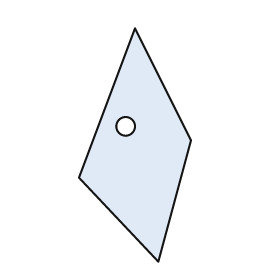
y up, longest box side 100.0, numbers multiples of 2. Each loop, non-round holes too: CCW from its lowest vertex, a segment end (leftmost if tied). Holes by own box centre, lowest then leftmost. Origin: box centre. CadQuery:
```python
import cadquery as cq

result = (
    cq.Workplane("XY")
    .moveTo(10.0, -50.0)
    .lineTo(24.0, 2.0)
    .lineTo(0.0, 50.0)
    .lineTo(-24.0, -14.0)
    .close()
    .moveTo(-4.0, 8.0)
    .circle(4.0)
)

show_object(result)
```